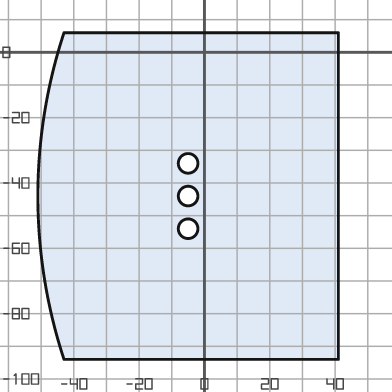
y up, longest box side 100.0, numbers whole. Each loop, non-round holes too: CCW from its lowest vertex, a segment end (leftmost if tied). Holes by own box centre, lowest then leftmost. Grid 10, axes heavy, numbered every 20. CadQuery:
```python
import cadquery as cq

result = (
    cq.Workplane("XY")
    .moveTo(-43.0, -94.0)
    .lineTo(41.0, -94.0)
    .lineTo(41.0, 6.0)
    .lineTo(-43.0, 6.0)
    .threePointArc((-51.0, -44.0), (-43.0, -94.0))
    .close()
    .moveTo(-5.0, -54.0)
    .circle(3.0)
    .moveTo(-5.0, -44.0)
    .circle(3.0)
    .moveTo(-5.0, -34.0)
    .circle(3.0)
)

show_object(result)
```